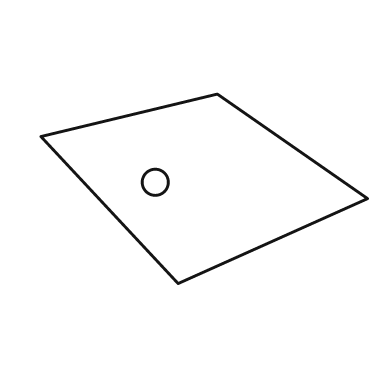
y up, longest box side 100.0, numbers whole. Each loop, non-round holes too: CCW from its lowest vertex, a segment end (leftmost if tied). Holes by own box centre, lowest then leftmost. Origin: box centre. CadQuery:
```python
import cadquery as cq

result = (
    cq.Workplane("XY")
    .moveTo(-8.0, -29.0)
    .lineTo(50.0, -3.0)
    .lineTo(4.0, 29.0)
    .lineTo(-50.0, 16.0)
    .close()
    .moveTo(-15.0, 2.0)
    .circle(4.0)
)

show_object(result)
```